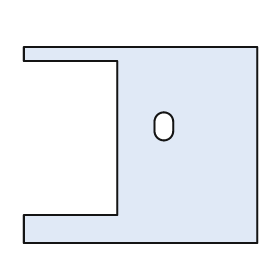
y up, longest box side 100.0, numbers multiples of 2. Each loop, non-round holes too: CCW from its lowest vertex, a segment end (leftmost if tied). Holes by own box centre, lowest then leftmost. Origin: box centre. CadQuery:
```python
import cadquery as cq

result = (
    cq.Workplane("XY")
    .moveTo(-50.0, -42.0)
    .lineTo(50.0, -42.0)
    .lineTo(50.0, 42.0)
    .lineTo(-50.0, 42.0)
    .lineTo(-50.0, 36.0)
    .lineTo(-10.0, 36.0)
    .lineTo(-10.0, -30.0)
    .lineTo(-50.0, -30.0)
    .close()
    .moveTo(6.0, 6.0)
    .threePointArc((10.0, 2.0), (14.0, 6.0))
    .lineTo(14.0, 10.0)
    .threePointArc((10.0, 14.0), (6.0, 10.0))
    .close()
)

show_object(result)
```